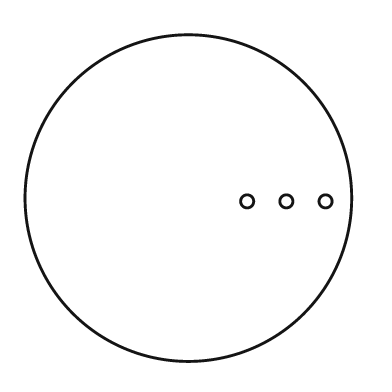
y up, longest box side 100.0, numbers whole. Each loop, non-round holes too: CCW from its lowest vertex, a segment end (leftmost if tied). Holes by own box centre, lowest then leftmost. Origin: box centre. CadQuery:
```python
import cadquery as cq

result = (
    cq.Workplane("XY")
    .moveTo(0.0, 0.0)
    .circle(50.0)
    .moveTo(18.0, -1.0)
    .circle(2.0)
    .moveTo(30.0, -1.0)
    .circle(2.0)
    .moveTo(42.0, -1.0)
    .circle(2.0)
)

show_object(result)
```